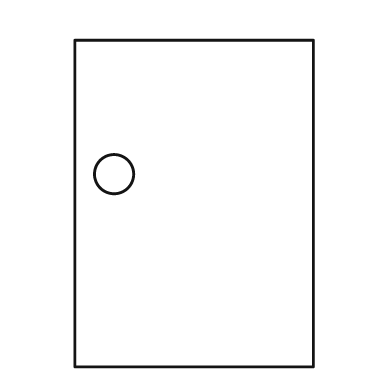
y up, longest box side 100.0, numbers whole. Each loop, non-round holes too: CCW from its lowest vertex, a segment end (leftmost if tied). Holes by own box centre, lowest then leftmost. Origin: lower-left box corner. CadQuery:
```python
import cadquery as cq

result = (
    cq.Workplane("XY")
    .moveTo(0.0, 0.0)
    .lineTo(73.0, 0.0)
    .lineTo(73.0, 100.0)
    .lineTo(0.0, 100.0)
    .close()
    .moveTo(12.0, 59.0)
    .circle(6.0)
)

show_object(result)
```